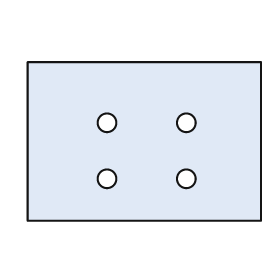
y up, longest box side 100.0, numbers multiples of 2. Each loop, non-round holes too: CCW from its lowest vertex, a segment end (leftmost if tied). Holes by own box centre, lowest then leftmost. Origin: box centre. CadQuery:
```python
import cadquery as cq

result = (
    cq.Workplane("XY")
    .moveTo(-50.0, -34.0)
    .lineTo(50.0, -34.0)
    .lineTo(50.0, 34.0)
    .lineTo(-50.0, 34.0)
    .close()
    .moveTo(-16.0, -16.0)
    .circle(4.0)
    .moveTo(18.0, -16.0)
    .circle(4.0)
    .moveTo(-16.0, 8.0)
    .circle(4.0)
    .moveTo(18.0, 8.0)
    .circle(4.0)
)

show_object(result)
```